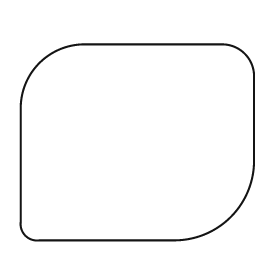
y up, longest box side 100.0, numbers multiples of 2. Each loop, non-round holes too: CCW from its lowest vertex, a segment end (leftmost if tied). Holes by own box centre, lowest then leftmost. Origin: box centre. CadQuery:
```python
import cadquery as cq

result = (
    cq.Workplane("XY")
    .moveTo(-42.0, -42.0)
    .lineTo(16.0, -42.0)
    .threePointArc((40.0, -32.0), (50.0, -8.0))
    .lineTo(50.0, 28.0)
    .threePointArc((46.0, 38.0), (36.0, 42.0))
    .lineTo(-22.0, 42.0)
    .threePointArc((-42.0, 34.0), (-50.0, 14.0))
    .lineTo(-50.0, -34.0)
    .threePointArc((-48.0, -40.0), (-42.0, -42.0))
    .close()
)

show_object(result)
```